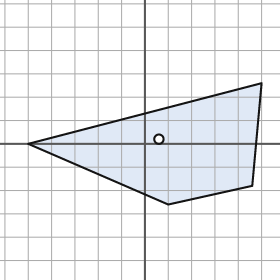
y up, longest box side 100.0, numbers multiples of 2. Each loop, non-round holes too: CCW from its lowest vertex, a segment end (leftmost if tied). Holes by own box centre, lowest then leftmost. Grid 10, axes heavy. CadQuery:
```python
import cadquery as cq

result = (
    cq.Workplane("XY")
    .moveTo(10.0, -26.0)
    .lineTo(46.0, -18.0)
    .lineTo(50.0, 26.0)
    .lineTo(-50.0, 0.0)
    .close()
    .moveTo(6.0, 2.0)
    .circle(2.0)
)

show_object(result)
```